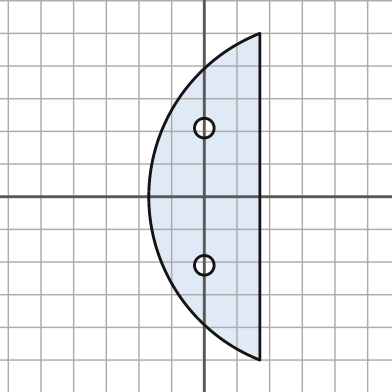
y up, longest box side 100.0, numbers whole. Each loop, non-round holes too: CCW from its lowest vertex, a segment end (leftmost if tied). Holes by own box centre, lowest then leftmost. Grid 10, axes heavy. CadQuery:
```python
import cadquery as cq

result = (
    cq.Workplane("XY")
    .moveTo(17.0, -50.0)
    .lineTo(17.0, 50.0)
    .threePointArc((-17.0, 0.0), (17.0, -50.0))
    .close()
    .moveTo(0.0, -21.0)
    .circle(3.0)
    .moveTo(0.0, 21.0)
    .circle(3.0)
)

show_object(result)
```